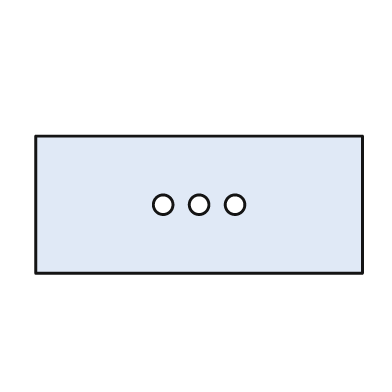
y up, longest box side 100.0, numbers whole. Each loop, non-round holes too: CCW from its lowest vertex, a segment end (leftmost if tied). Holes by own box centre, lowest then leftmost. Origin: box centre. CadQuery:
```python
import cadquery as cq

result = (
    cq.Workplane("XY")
    .moveTo(-50.0, -21.0)
    .lineTo(50.0, -21.0)
    .lineTo(50.0, 21.0)
    .lineTo(-50.0, 21.0)
    .close()
    .moveTo(-11.0, 0.0)
    .circle(3.0)
    .moveTo(0.0, 0.0)
    .circle(3.0)
    .moveTo(11.0, 0.0)
    .circle(3.0)
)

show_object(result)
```